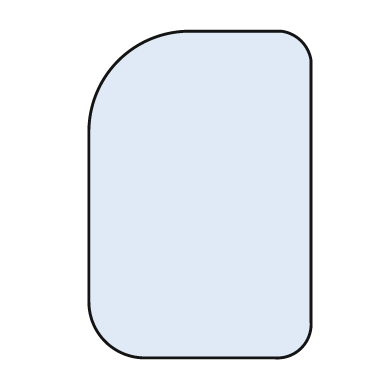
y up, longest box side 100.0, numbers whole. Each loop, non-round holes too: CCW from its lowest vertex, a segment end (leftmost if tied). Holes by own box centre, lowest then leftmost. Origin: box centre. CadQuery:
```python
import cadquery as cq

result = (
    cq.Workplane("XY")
    .moveTo(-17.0, -50.0)
    .lineTo(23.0, -50.0)
    .threePointArc((31.0, -47.0), (34.0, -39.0))
    .lineTo(34.0, 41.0)
    .threePointArc((31.0, 47.0), (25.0, 50.0))
    .lineTo(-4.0, 50.0)
    .threePointArc((-25.0, 41.0), (-34.0, 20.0))
    .lineTo(-34.0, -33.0)
    .threePointArc((-29.0, -45.0), (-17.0, -50.0))
    .close()
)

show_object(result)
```